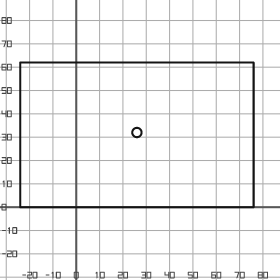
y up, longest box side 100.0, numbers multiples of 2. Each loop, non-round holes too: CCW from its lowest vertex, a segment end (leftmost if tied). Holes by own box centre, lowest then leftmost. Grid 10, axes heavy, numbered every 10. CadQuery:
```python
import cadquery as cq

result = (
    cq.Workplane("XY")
    .moveTo(-24.0, 0.0)
    .lineTo(76.0, 0.0)
    .lineTo(76.0, 62.0)
    .lineTo(-24.0, 62.0)
    .close()
    .moveTo(26.0, 32.0)
    .circle(2.0)
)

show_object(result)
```